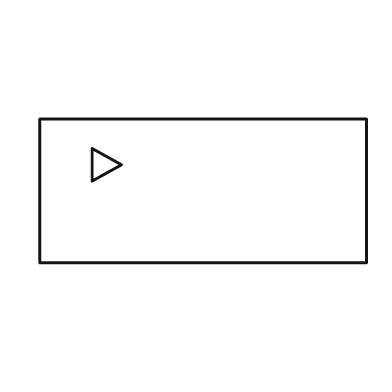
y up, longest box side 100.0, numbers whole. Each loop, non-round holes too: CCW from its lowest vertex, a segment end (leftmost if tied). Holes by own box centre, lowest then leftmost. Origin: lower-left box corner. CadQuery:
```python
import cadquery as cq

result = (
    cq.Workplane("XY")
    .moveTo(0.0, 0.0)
    .lineTo(100.0, 0.0)
    .lineTo(100.0, 44.0)
    .lineTo(0.0, 44.0)
    .close()
    .moveTo(16.0, 25.0)
    .lineTo(25.0, 30.0)
    .lineTo(16.0, 35.0)
    .close()
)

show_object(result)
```